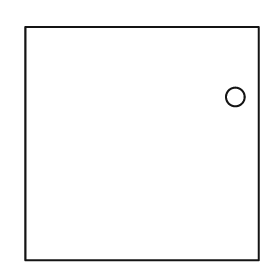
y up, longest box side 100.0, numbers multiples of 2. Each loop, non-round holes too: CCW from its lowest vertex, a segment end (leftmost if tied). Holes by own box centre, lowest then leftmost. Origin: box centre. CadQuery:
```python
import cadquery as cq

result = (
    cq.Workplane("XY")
    .moveTo(-50.0, -50.0)
    .lineTo(50.0, -50.0)
    .lineTo(50.0, 50.0)
    .lineTo(-50.0, 50.0)
    .close()
    .moveTo(40.0, 20.0)
    .circle(4.0)
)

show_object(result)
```